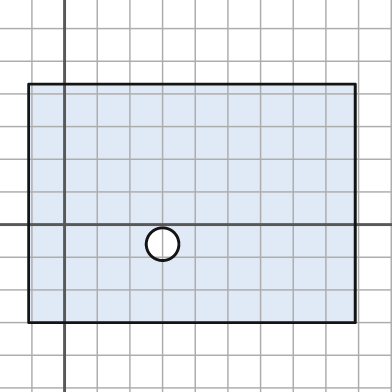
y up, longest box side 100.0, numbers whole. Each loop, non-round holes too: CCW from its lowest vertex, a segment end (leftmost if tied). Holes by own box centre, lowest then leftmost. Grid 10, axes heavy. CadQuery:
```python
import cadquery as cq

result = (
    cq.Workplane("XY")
    .moveTo(-11.0, -30.0)
    .lineTo(89.0, -30.0)
    .lineTo(89.0, 43.0)
    .lineTo(-11.0, 43.0)
    .close()
    .moveTo(30.0, -6.0)
    .circle(5.0)
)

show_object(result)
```